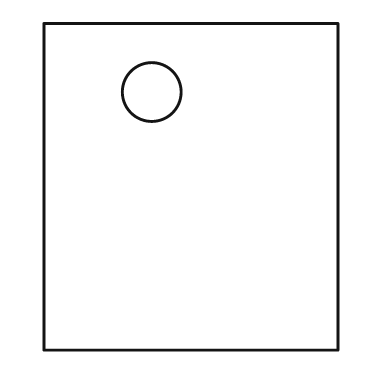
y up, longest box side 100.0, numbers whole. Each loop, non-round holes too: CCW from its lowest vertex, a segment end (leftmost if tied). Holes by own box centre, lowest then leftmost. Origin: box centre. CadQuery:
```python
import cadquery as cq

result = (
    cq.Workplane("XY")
    .moveTo(-45.0, -50.0)
    .lineTo(45.0, -50.0)
    .lineTo(45.0, 50.0)
    .lineTo(-45.0, 50.0)
    .close()
    .moveTo(-12.0, 29.0)
    .circle(9.0)
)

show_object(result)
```